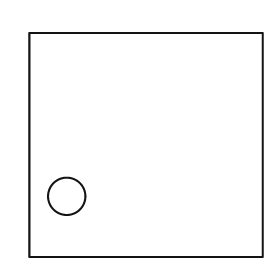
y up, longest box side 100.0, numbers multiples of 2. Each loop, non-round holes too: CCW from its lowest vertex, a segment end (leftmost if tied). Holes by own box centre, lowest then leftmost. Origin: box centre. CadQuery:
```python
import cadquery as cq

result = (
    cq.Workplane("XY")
    .moveTo(-50.0, -48.0)
    .lineTo(50.0, -48.0)
    .lineTo(50.0, 48.0)
    .lineTo(-50.0, 48.0)
    .close()
    .moveTo(-34.0, -22.0)
    .circle(8.0)
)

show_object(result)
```